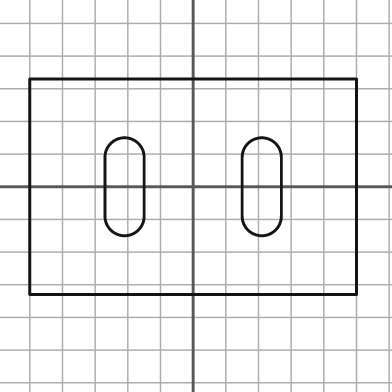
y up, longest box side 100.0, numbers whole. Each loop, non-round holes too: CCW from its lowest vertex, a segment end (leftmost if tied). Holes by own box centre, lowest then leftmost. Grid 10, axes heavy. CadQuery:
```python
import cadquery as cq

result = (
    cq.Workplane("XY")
    .moveTo(-50.0, -33.0)
    .lineTo(50.0, -33.0)
    .lineTo(50.0, 33.0)
    .lineTo(-50.0, 33.0)
    .close()
    .moveTo(-27.0, -9.0)
    .threePointArc((-21.0, -15.0), (-15.0, -9.0))
    .lineTo(-15.0, 9.0)
    .threePointArc((-21.0, 15.0), (-27.0, 9.0))
    .close()
    .moveTo(15.0, -9.0)
    .threePointArc((21.0, -15.0), (27.0, -9.0))
    .lineTo(27.0, 9.0)
    .threePointArc((21.0, 15.0), (15.0, 9.0))
    .close()
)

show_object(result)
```